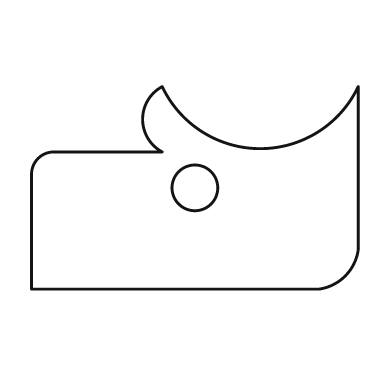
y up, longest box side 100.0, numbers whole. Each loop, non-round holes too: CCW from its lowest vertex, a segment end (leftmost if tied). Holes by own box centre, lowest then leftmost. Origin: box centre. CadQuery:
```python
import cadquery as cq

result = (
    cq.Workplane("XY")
    .moveTo(-50.0, -31.0)
    .lineTo(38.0, -31.0)
    .threePointArc((46.0, -27.0), (50.0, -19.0))
    .lineTo(50.0, 31.0)
    .threePointArc((20.0, 12.0), (-10.0, 31.0))
    .threePointArc((-16.0, 21.0), (-10.0, 11.0))
    .lineTo(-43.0, 11.0)
    .threePointArc((-48.0, 9.0), (-50.0, 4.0))
    .close()
    .moveTo(0.0, 0.0)
    .circle(7.0)
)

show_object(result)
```